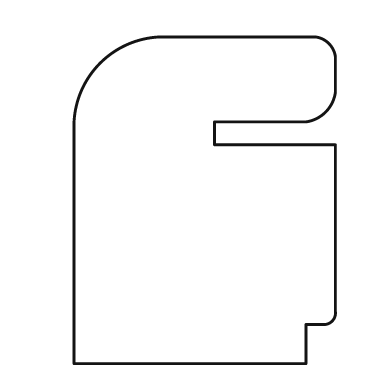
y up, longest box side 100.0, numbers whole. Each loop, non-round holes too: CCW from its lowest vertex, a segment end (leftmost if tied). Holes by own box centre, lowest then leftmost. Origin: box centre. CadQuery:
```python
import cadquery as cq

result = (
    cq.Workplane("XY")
    .moveTo(-40.0, -50.0)
    .lineTo(31.0, -50.0)
    .lineTo(31.0, -38.0)
    .lineTo(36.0, -38.0)
    .threePointArc((39.0, -37.0), (40.0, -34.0))
    .lineTo(40.0, 17.0)
    .lineTo(3.0, 17.0)
    .lineTo(3.0, 24.0)
    .lineTo(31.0, 24.0)
    .threePointArc((37.0, 27.0), (40.0, 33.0))
    .lineTo(40.0, 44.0)
    .threePointArc((38.0, 48.0), (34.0, 50.0))
    .lineTo(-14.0, 50.0)
    .threePointArc((-32.0, 42.0), (-40.0, 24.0))
    .close()
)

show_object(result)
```